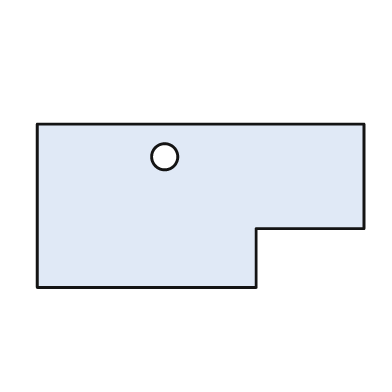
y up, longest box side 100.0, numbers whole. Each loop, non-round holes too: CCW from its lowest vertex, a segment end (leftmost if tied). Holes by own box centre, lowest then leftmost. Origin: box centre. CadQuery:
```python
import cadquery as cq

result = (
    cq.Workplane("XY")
    .moveTo(-50.0, -25.0)
    .lineTo(17.0, -25.0)
    .lineTo(17.0, -7.0)
    .lineTo(50.0, -7.0)
    .lineTo(50.0, 25.0)
    .lineTo(-50.0, 25.0)
    .close()
    .moveTo(-11.0, 15.0)
    .circle(4.0)
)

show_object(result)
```